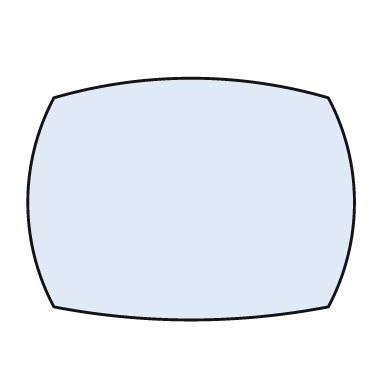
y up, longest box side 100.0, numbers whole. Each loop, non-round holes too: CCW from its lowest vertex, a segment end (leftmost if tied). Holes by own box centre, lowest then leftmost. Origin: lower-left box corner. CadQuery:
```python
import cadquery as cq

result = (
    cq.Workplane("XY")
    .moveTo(8.0, 4.0)
    .threePointArc((50.0, 0.0), (92.0, 4.0))
    .threePointArc((100.0, 36.0), (92.0, 68.0))
    .threePointArc((50.0, 74.0), (8.0, 68.0))
    .threePointArc((0.0, 36.0), (8.0, 4.0))
    .close()
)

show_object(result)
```